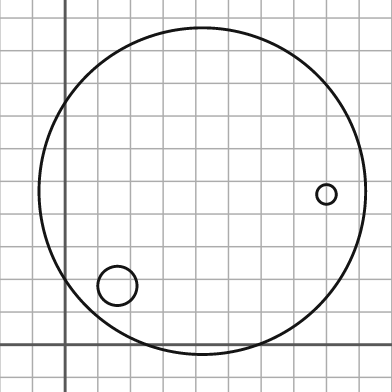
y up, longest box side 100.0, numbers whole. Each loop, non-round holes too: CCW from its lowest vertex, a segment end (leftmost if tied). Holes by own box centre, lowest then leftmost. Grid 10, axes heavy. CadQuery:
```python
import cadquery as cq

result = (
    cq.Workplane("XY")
    .moveTo(42.0, 47.0)
    .circle(50.0)
    .moveTo(16.0, 18.0)
    .circle(6.0)
    .moveTo(80.0, 46.0)
    .circle(3.0)
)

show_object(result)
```